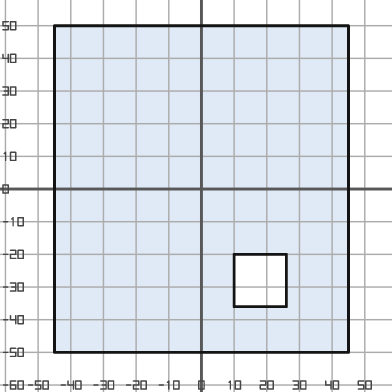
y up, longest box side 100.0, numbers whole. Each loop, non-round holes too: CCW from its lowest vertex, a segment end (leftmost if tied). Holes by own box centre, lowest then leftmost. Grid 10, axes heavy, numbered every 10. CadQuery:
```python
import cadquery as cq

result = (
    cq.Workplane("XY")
    .moveTo(-45.0, -50.0)
    .lineTo(45.0, -50.0)
    .lineTo(45.0, 50.0)
    .lineTo(-45.0, 50.0)
    .close()
    .moveTo(10.0, -36.0)
    .lineTo(26.0, -36.0)
    .lineTo(26.0, -20.0)
    .lineTo(10.0, -20.0)
    .close()
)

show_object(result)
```